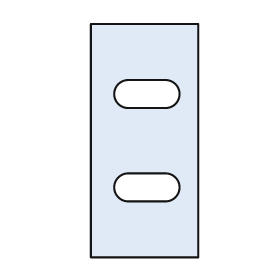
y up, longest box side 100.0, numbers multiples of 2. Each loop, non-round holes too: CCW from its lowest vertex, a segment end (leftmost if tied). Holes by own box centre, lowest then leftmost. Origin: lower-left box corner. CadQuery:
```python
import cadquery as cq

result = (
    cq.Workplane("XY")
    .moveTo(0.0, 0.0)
    .lineTo(46.0, 0.0)
    .lineTo(46.0, 100.0)
    .lineTo(0.0, 100.0)
    .close()
    .moveTo(16.0, 24.0)
    .lineTo(32.0, 24.0)
    .threePointArc((38.0, 30.0), (32.0, 36.0))
    .lineTo(16.0, 36.0)
    .threePointArc((10.0, 30.0), (16.0, 24.0))
    .close()
    .moveTo(16.0, 64.0)
    .lineTo(32.0, 64.0)
    .threePointArc((38.0, 70.0), (32.0, 76.0))
    .lineTo(16.0, 76.0)
    .threePointArc((10.0, 70.0), (16.0, 64.0))
    .close()
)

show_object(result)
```